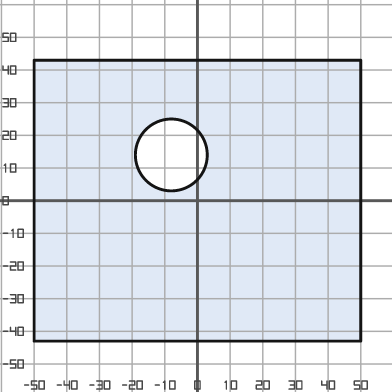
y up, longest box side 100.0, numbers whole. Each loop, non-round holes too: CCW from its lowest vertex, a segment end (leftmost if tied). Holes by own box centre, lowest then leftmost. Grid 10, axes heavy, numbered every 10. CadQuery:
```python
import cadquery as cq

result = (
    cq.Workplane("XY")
    .moveTo(-50.0, -43.0)
    .lineTo(50.0, -43.0)
    .lineTo(50.0, 43.0)
    .lineTo(-50.0, 43.0)
    .close()
    .moveTo(-8.0, 14.0)
    .circle(11.0)
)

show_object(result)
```